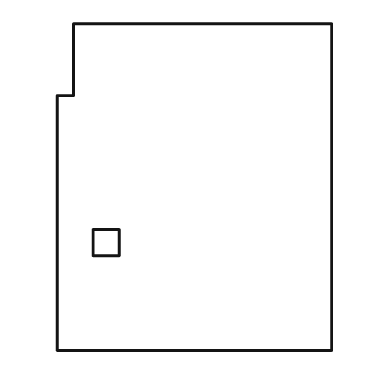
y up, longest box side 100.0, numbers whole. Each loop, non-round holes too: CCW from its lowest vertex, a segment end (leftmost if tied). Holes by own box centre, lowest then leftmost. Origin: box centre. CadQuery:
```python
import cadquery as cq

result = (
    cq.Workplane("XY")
    .moveTo(-42.0, -50.0)
    .lineTo(42.0, -50.0)
    .lineTo(42.0, 50.0)
    .lineTo(-37.0, 50.0)
    .lineTo(-37.0, 28.0)
    .lineTo(-42.0, 28.0)
    .close()
    .moveTo(-31.0, -21.0)
    .lineTo(-23.0, -21.0)
    .lineTo(-23.0, -13.0)
    .lineTo(-31.0, -13.0)
    .close()
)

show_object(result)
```